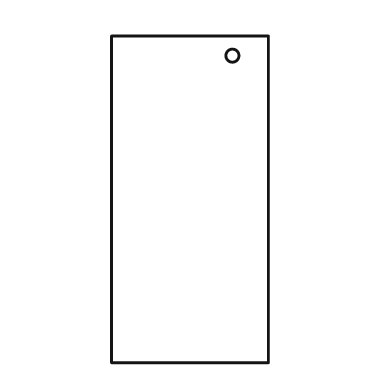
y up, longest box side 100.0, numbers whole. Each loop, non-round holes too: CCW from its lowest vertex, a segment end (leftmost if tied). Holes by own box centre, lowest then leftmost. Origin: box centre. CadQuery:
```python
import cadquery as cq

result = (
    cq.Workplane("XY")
    .moveTo(-24.0, -50.0)
    .lineTo(24.0, -50.0)
    .lineTo(24.0, 50.0)
    .lineTo(-24.0, 50.0)
    .close()
    .moveTo(13.0, 44.0)
    .circle(2.0)
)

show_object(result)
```